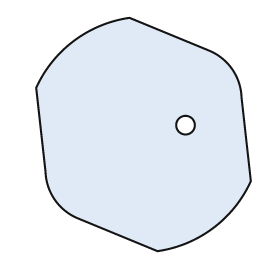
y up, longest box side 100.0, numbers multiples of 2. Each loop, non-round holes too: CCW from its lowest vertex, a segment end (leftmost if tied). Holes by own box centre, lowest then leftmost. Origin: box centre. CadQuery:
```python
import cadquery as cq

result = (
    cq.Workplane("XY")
    .moveTo(6.0, -50.0)
    .threePointArc((30.0, -40.0), (46.0, -20.0))
    .lineTo(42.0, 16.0)
    .threePointArc((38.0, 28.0), (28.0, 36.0))
    .lineTo(-6.0, 50.0)
    .threePointArc((-30.0, 40.0), (-46.0, 20.0))
    .lineTo(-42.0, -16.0)
    .threePointArc((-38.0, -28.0), (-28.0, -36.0))
    .close()
    .moveTo(18.0, 4.0)
    .circle(4.0)
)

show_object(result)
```